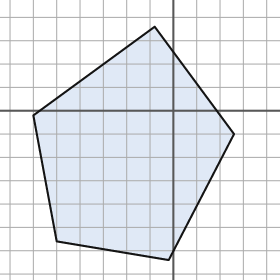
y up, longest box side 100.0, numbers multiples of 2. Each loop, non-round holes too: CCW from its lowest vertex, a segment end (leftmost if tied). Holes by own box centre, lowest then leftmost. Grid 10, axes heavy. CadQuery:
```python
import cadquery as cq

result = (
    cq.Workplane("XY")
    .moveTo(-2.0, -64.0)
    .lineTo(26.0, -10.0)
    .lineTo(-8.0, 36.0)
    .lineTo(-60.0, -2.0)
    .lineTo(-50.0, -56.0)
    .close()
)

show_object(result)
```